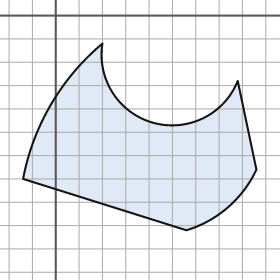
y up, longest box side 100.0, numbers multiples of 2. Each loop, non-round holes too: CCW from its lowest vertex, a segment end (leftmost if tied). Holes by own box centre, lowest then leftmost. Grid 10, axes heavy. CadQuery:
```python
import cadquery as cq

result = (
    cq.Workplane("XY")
    .moveTo(56.0, -92.0)
    .threePointArc((74.0, -82.0), (86.0, -66.0))
    .lineTo(78.0, -28.0)
    .threePointArc((42.0, -46.0), (20.0, -12.0))
    .threePointArc((-2.0, -38.0), (-14.0, -70.0))
    .close()
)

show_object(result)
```